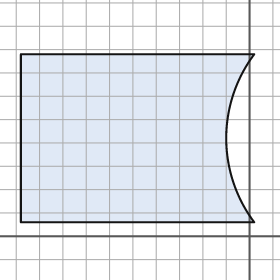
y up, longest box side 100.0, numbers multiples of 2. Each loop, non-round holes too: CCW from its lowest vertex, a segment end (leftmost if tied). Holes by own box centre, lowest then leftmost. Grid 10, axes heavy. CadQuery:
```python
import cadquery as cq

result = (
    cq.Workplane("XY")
    .moveTo(-98.0, 6.0)
    .lineTo(2.0, 6.0)
    .threePointArc((-10.0, 42.0), (2.0, 78.0))
    .lineTo(-98.0, 78.0)
    .close()
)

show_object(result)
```